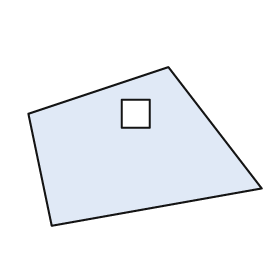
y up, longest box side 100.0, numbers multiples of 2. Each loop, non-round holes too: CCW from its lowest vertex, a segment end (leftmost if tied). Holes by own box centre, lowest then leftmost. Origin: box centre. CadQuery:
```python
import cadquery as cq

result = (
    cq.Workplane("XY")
    .moveTo(-40.0, -34.0)
    .lineTo(50.0, -18.0)
    .lineTo(10.0, 34.0)
    .lineTo(-50.0, 14.0)
    .close()
    .moveTo(-10.0, 8.0)
    .lineTo(2.0, 8.0)
    .lineTo(2.0, 20.0)
    .lineTo(-10.0, 20.0)
    .close()
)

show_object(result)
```